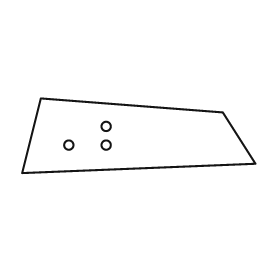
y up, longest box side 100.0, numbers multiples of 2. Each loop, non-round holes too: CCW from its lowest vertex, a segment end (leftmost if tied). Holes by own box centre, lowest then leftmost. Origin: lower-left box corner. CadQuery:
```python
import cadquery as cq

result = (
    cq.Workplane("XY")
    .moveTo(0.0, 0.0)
    .lineTo(100.0, 4.0)
    .lineTo(86.0, 26.0)
    .lineTo(8.0, 32.0)
    .close()
    .moveTo(20.0, 12.0)
    .circle(2.0)
    .moveTo(36.0, 12.0)
    .circle(2.0)
    .moveTo(36.0, 20.0)
    .circle(2.0)
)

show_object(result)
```